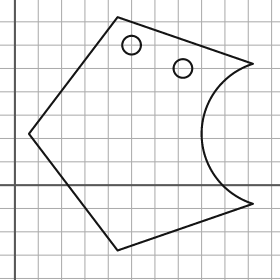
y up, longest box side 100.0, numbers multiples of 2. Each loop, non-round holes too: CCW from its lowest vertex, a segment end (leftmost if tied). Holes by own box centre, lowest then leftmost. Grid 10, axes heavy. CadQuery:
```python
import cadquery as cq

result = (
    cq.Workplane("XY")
    .moveTo(44.0, -28.0)
    .lineTo(102.0, -8.0)
    .threePointArc((80.0, 22.0), (102.0, 52.0))
    .lineTo(44.0, 72.0)
    .lineTo(6.0, 22.0)
    .close()
    .moveTo(72.0, 50.0)
    .circle(4.0)
    .moveTo(50.0, 60.0)
    .circle(4.0)
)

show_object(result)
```